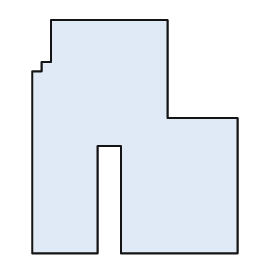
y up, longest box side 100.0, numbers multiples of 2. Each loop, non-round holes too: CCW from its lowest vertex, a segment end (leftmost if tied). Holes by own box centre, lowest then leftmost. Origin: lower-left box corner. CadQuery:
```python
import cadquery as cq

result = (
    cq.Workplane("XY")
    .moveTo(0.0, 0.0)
    .lineTo(28.0, 0.0)
    .lineTo(28.0, 46.0)
    .lineTo(38.0, 46.0)
    .lineTo(38.0, 0.0)
    .lineTo(88.0, 0.0)
    .lineTo(88.0, 58.0)
    .lineTo(58.0, 58.0)
    .lineTo(58.0, 100.0)
    .lineTo(8.0, 100.0)
    .lineTo(8.0, 82.0)
    .lineTo(4.0, 82.0)
    .lineTo(4.0, 78.0)
    .lineTo(0.0, 78.0)
    .close()
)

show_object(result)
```